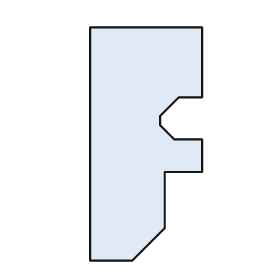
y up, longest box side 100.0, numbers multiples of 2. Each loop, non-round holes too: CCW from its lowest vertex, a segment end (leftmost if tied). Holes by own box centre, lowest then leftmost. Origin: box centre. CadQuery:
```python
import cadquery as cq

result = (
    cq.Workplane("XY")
    .moveTo(-24.0, -50.0)
    .lineTo(-6.0, -50.0)
    .lineTo(8.0, -36.0)
    .lineTo(8.0, -12.0)
    .lineTo(24.0, -12.0)
    .lineTo(24.0, 2.0)
    .lineTo(12.0, 2.0)
    .lineTo(6.0, 8.0)
    .lineTo(6.0, 12.0)
    .lineTo(14.0, 20.0)
    .lineTo(24.0, 20.0)
    .lineTo(24.0, 50.0)
    .lineTo(-24.0, 50.0)
    .close()
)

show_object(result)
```